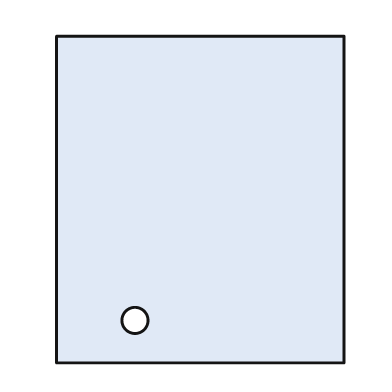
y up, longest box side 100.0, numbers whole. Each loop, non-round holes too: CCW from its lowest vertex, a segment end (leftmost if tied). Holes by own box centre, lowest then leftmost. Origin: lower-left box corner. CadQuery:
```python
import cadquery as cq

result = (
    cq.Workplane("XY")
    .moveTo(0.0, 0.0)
    .lineTo(88.0, 0.0)
    .lineTo(88.0, 100.0)
    .lineTo(0.0, 100.0)
    .close()
    .moveTo(24.0, 13.0)
    .circle(4.0)
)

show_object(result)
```